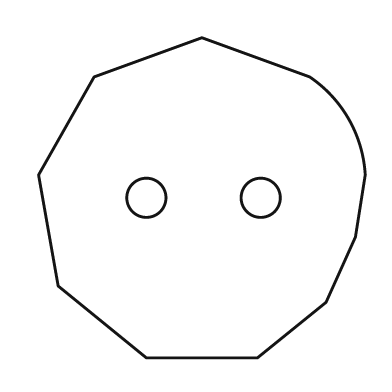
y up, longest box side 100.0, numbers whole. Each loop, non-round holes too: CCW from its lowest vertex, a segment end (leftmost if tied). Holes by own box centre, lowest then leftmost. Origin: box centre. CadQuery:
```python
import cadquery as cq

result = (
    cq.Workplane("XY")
    .moveTo(-17.0, -49.0)
    .lineTo(17.0, -49.0)
    .lineTo(38.0, -32.0)
    .lineTo(47.0, -12.0)
    .lineTo(50.0, 7.0)
    .threePointArc((45.0, 24.0), (33.0, 37.0))
    .lineTo(0.0, 49.0)
    .lineTo(-33.0, 37.0)
    .lineTo(-50.0, 7.0)
    .lineTo(-44.0, -27.0)
    .close()
    .moveTo(-17.0, 0.0)
    .circle(6.0)
    .moveTo(18.0, 0.0)
    .circle(6.0)
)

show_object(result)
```